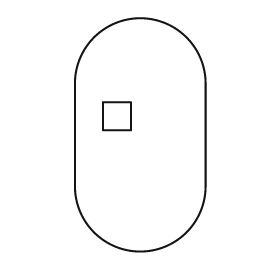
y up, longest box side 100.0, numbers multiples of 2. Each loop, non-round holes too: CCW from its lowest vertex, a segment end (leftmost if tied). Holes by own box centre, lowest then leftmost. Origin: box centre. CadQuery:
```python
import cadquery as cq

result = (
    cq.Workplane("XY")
    .moveTo(-28.0, -22.0)
    .threePointArc((0.0, -50.0), (28.0, -22.0))
    .lineTo(28.0, 22.0)
    .threePointArc((0.0, 50.0), (-28.0, 22.0))
    .close()
    .moveTo(-16.0, 2.0)
    .lineTo(-4.0, 2.0)
    .lineTo(-4.0, 14.0)
    .lineTo(-16.0, 14.0)
    .close()
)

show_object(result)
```